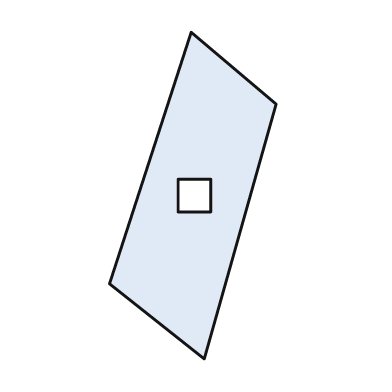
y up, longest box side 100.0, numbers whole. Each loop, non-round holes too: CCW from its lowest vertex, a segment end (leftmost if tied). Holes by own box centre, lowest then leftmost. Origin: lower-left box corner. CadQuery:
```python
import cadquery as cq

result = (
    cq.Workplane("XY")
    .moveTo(29.0, 0.0)
    .lineTo(51.0, 78.0)
    .lineTo(25.0, 100.0)
    .lineTo(0.0, 23.0)
    .close()
    .moveTo(21.0, 45.0)
    .lineTo(31.0, 45.0)
    .lineTo(31.0, 55.0)
    .lineTo(21.0, 55.0)
    .close()
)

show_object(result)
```